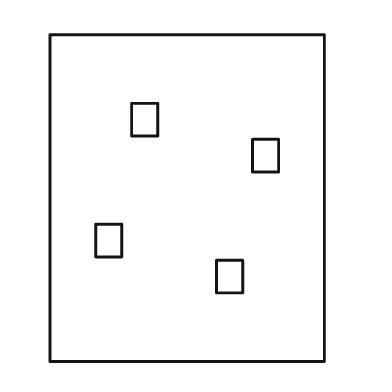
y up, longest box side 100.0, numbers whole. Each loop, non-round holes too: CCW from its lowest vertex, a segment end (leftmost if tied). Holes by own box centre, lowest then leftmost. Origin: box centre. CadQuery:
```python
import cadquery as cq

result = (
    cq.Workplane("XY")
    .moveTo(-42.0, -50.0)
    .lineTo(42.0, -50.0)
    .lineTo(42.0, 50.0)
    .lineTo(-42.0, 50.0)
    .close()
    .moveTo(9.0, -29.0)
    .lineTo(17.0, -29.0)
    .lineTo(17.0, -19.0)
    .lineTo(9.0, -19.0)
    .close()
    .moveTo(-28.0, -18.0)
    .lineTo(-20.0, -18.0)
    .lineTo(-20.0, -8.0)
    .lineTo(-28.0, -8.0)
    .close()
    .moveTo(20.0, 8.0)
    .lineTo(28.0, 8.0)
    .lineTo(28.0, 18.0)
    .lineTo(20.0, 18.0)
    .close()
    .moveTo(-17.0, 19.0)
    .lineTo(-9.0, 19.0)
    .lineTo(-9.0, 29.0)
    .lineTo(-17.0, 29.0)
    .close()
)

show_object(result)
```